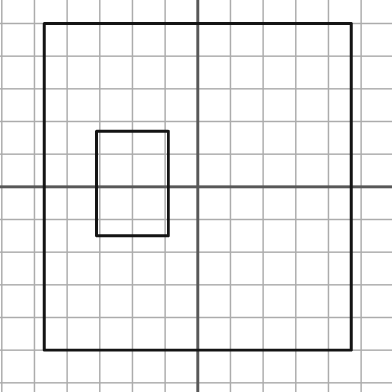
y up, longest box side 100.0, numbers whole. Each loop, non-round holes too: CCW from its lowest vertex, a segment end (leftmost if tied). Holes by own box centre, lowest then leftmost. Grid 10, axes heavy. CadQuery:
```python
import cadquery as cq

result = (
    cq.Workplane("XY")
    .moveTo(-47.0, -50.0)
    .lineTo(47.0, -50.0)
    .lineTo(47.0, 50.0)
    .lineTo(-47.0, 50.0)
    .close()
    .moveTo(-31.0, -15.0)
    .lineTo(-9.0, -15.0)
    .lineTo(-9.0, 17.0)
    .lineTo(-31.0, 17.0)
    .close()
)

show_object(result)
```